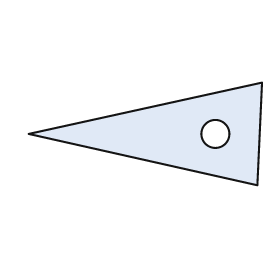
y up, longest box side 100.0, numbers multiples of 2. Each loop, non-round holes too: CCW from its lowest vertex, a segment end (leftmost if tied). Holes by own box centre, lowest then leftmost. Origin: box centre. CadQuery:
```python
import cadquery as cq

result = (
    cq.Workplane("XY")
    .moveTo(48.0, -22.0)
    .lineTo(50.0, 22.0)
    .lineTo(-50.0, 0.0)
    .close()
    .moveTo(30.0, 0.0)
    .circle(6.0)
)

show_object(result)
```